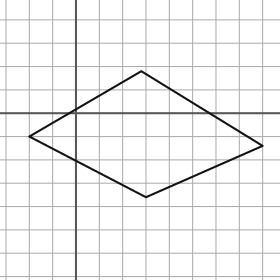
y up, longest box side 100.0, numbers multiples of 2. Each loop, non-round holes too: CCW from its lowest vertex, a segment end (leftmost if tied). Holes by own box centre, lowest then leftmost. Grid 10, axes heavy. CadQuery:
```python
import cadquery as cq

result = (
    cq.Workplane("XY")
    .moveTo(30.0, -36.0)
    .lineTo(80.0, -14.0)
    .lineTo(28.0, 18.0)
    .lineTo(-20.0, -10.0)
    .close()
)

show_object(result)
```